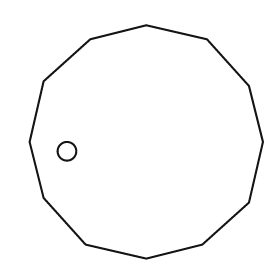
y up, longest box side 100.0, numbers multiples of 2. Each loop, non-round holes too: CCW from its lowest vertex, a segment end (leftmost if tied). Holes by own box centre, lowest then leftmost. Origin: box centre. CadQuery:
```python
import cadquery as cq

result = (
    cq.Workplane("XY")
    .moveTo(0.0, -50.0)
    .lineTo(24.0, -44.0)
    .lineTo(44.0, -26.0)
    .lineTo(50.0, 0.0)
    .lineTo(44.0, 24.0)
    .lineTo(26.0, 44.0)
    .lineTo(0.0, 50.0)
    .lineTo(-24.0, 44.0)
    .lineTo(-44.0, 26.0)
    .lineTo(-50.0, 0.0)
    .lineTo(-44.0, -24.0)
    .lineTo(-26.0, -44.0)
    .close()
    .moveTo(-34.0, -4.0)
    .circle(4.0)
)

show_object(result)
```